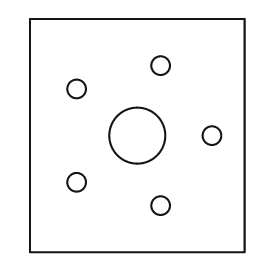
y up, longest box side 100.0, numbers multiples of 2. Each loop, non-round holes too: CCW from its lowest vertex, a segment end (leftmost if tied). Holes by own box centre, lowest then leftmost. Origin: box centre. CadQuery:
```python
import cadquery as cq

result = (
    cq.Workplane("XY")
    .moveTo(-46.0, -50.0)
    .lineTo(46.0, -50.0)
    .lineTo(46.0, 50.0)
    .lineTo(-46.0, 50.0)
    .close()
    .moveTo(10.0, -30.0)
    .circle(4.0)
    .moveTo(-26.0, -20.0)
    .circle(4.0)
    .moveTo(0.0, 0.0)
    .circle(12.0)
    .moveTo(32.0, 0.0)
    .circle(4.0)
    .moveTo(-26.0, 20.0)
    .circle(4.0)
    .moveTo(10.0, 30.0)
    .circle(4.0)
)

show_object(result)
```